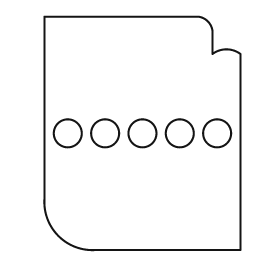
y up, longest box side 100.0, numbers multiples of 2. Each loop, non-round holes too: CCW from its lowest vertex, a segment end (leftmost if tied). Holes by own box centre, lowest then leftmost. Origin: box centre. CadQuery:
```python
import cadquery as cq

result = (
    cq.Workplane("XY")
    .moveTo(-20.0, -50.0)
    .lineTo(42.0, -50.0)
    .lineTo(42.0, 34.0)
    .threePointArc((36.0, 36.0), (30.0, 34.0))
    .lineTo(30.0, 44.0)
    .threePointArc((28.0, 48.0), (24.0, 50.0))
    .lineTo(-42.0, 50.0)
    .lineTo(-42.0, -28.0)
    .threePointArc((-36.0, -44.0), (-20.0, -50.0))
    .close()
    .moveTo(-32.0, 0.0)
    .circle(6.0)
    .moveTo(-16.0, 0.0)
    .circle(6.0)
    .moveTo(0.0, 0.0)
    .circle(6.0)
    .moveTo(16.0, 0.0)
    .circle(6.0)
    .moveTo(32.0, 0.0)
    .circle(6.0)
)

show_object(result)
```